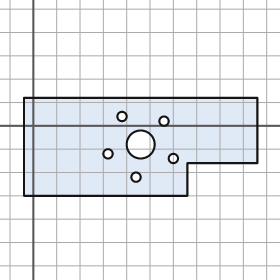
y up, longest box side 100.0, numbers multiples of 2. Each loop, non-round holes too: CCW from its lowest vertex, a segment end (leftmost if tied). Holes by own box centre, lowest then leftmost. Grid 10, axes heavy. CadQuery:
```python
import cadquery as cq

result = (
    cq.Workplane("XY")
    .moveTo(-4.0, -30.0)
    .lineTo(66.0, -30.0)
    .lineTo(66.0, -16.0)
    .lineTo(96.0, -16.0)
    .lineTo(96.0, 12.0)
    .lineTo(-4.0, 12.0)
    .close()
    .moveTo(44.0, -22.0)
    .circle(2.0)
    .moveTo(60.0, -14.0)
    .circle(2.0)
    .moveTo(32.0, -12.0)
    .circle(2.0)
    .moveTo(46.0, -8.0)
    .circle(6.0)
    .moveTo(56.0, 2.0)
    .circle(2.0)
    .moveTo(38.0, 4.0)
    .circle(2.0)
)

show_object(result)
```